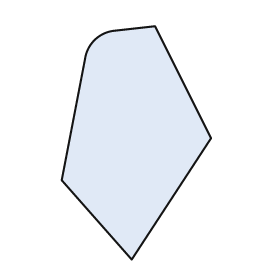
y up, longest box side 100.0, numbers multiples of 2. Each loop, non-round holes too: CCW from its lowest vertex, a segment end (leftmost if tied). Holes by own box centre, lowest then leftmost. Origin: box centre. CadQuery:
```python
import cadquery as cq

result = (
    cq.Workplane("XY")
    .moveTo(-2.0, -50.0)
    .lineTo(32.0, 2.0)
    .lineTo(8.0, 50.0)
    .lineTo(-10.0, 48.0)
    .threePointArc((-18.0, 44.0), (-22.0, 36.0))
    .lineTo(-32.0, -16.0)
    .close()
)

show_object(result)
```